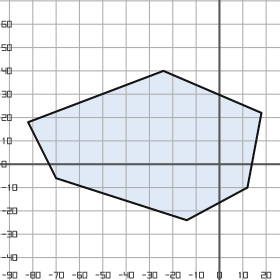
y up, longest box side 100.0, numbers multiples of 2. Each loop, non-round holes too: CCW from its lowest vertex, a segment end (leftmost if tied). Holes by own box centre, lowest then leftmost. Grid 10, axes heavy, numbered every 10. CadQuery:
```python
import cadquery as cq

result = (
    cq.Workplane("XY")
    .moveTo(-14.0, -24.0)
    .lineTo(12.0, -10.0)
    .lineTo(18.0, 22.0)
    .lineTo(-24.0, 40.0)
    .lineTo(-82.0, 18.0)
    .lineTo(-70.0, -6.0)
    .close()
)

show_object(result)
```